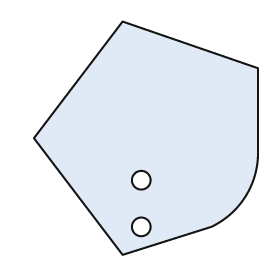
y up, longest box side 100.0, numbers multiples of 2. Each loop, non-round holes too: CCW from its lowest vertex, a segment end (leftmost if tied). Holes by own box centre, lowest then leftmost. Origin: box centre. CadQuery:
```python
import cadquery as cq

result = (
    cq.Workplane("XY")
    .moveTo(-10.0, -50.0)
    .lineTo(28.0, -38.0)
    .threePointArc((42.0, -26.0), (48.0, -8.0))
    .lineTo(48.0, 30.0)
    .lineTo(-10.0, 50.0)
    .lineTo(-48.0, 0.0)
    .close()
    .moveTo(-2.0, -38.0)
    .circle(4.0)
    .moveTo(-2.0, -18.0)
    .circle(4.0)
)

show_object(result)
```